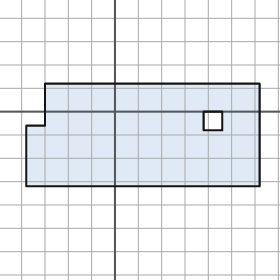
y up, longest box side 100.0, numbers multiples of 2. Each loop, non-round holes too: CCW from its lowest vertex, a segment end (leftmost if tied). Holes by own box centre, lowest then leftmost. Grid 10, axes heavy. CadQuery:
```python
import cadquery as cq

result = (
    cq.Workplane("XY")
    .moveTo(-38.0, -32.0)
    .lineTo(62.0, -32.0)
    .lineTo(62.0, 12.0)
    .lineTo(-30.0, 12.0)
    .lineTo(-30.0, -6.0)
    .lineTo(-38.0, -6.0)
    .close()
    .moveTo(38.0, -8.0)
    .lineTo(46.0, -8.0)
    .lineTo(46.0, 0.0)
    .lineTo(38.0, 0.0)
    .close()
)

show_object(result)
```